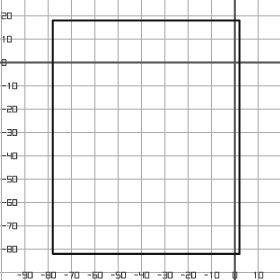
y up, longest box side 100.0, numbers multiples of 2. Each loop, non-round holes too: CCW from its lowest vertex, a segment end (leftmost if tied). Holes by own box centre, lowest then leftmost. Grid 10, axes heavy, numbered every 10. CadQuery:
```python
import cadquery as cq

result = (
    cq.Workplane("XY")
    .moveTo(-78.0, -82.0)
    .lineTo(2.0, -82.0)
    .lineTo(2.0, 18.0)
    .lineTo(-78.0, 18.0)
    .close()
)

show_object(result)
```